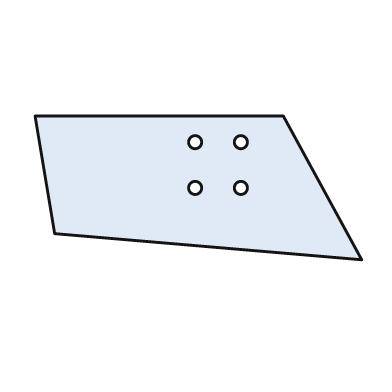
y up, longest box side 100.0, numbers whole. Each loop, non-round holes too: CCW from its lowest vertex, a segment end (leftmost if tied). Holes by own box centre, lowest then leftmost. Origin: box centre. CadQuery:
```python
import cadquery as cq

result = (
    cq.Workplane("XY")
    .moveTo(50.0, -22.0)
    .lineTo(26.0, 22.0)
    .lineTo(-50.0, 22.0)
    .lineTo(-44.0, -14.0)
    .close()
    .moveTo(-1.0, 0.0)
    .circle(2.0)
    .moveTo(13.0, 0.0)
    .circle(2.0)
    .moveTo(-1.0, 14.0)
    .circle(2.0)
    .moveTo(13.0, 14.0)
    .circle(2.0)
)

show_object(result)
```